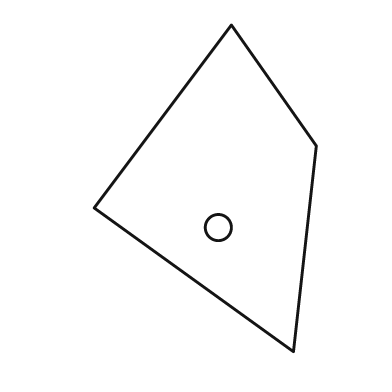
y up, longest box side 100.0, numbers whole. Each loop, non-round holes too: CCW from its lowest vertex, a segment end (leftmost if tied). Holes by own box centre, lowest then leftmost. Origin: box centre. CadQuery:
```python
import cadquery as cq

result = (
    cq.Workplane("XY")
    .moveTo(27.0, -50.0)
    .lineTo(34.0, 13.0)
    .lineTo(8.0, 50.0)
    .lineTo(-34.0, -6.0)
    .close()
    .moveTo(4.0, -12.0)
    .circle(4.0)
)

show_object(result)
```